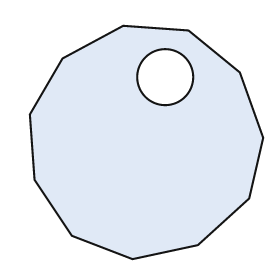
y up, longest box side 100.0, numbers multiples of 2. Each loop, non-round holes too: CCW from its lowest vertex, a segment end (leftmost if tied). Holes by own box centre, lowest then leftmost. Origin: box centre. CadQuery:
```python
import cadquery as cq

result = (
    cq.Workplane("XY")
    .moveTo(-6.0, -50.0)
    .lineTo(22.0, -44.0)
    .lineTo(44.0, -24.0)
    .lineTo(50.0, 2.0)
    .lineTo(40.0, 30.0)
    .lineTo(18.0, 48.0)
    .lineTo(-10.0, 50.0)
    .lineTo(-36.0, 36.0)
    .lineTo(-50.0, 12.0)
    .lineTo(-48.0, -16.0)
    .lineTo(-32.0, -40.0)
    .close()
    .moveTo(8.0, 28.0)
    .circle(12.0)
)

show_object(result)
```